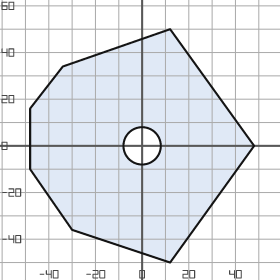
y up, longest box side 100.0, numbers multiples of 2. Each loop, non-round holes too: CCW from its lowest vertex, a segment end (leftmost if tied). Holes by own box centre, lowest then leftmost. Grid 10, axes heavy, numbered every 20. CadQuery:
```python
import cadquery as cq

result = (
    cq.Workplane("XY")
    .moveTo(12.0, -50.0)
    .lineTo(48.0, 0.0)
    .lineTo(12.0, 50.0)
    .lineTo(-34.0, 34.0)
    .lineTo(-48.0, 16.0)
    .lineTo(-48.0, -10.0)
    .lineTo(-30.0, -36.0)
    .close()
    .moveTo(0.0, 0.0)
    .circle(8.0)
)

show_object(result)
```